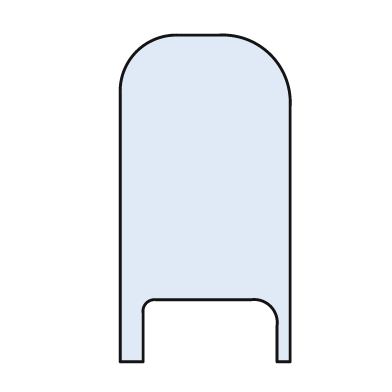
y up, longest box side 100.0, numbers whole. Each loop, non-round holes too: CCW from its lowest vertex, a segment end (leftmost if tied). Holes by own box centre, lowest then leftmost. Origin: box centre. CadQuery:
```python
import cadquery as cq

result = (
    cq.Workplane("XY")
    .moveTo(-26.0, -50.0)
    .lineTo(-19.0, -50.0)
    .lineTo(-19.0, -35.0)
    .threePointArc((-18.0, -32.0), (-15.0, -31.0))
    .lineTo(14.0, -31.0)
    .threePointArc((20.0, -33.0), (22.0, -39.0))
    .lineTo(22.0, -50.0)
    .lineTo(26.0, -50.0)
    .lineTo(26.0, 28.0)
    .threePointArc((20.0, 44.0), (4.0, 50.0))
    .lineTo(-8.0, 50.0)
    .threePointArc((-21.0, 45.0), (-26.0, 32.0))
    .close()
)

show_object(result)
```